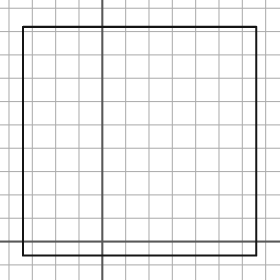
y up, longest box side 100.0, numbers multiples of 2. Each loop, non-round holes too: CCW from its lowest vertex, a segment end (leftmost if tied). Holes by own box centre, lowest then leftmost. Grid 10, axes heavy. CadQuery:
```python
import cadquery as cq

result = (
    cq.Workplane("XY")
    .moveTo(-34.0, -6.0)
    .lineTo(66.0, -6.0)
    .lineTo(66.0, 92.0)
    .lineTo(-34.0, 92.0)
    .close()
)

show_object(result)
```